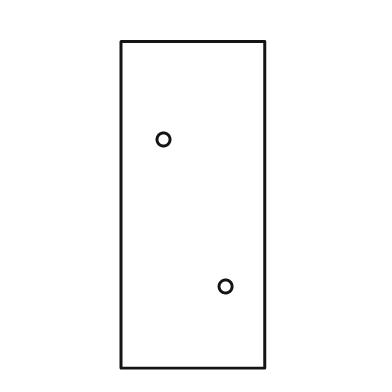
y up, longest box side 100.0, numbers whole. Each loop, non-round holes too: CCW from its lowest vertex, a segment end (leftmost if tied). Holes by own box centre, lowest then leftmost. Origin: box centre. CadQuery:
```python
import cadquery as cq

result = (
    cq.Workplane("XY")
    .moveTo(-22.0, -50.0)
    .lineTo(22.0, -50.0)
    .lineTo(22.0, 50.0)
    .lineTo(-22.0, 50.0)
    .close()
    .moveTo(10.0, -25.0)
    .circle(2.0)
    .moveTo(-9.0, 20.0)
    .circle(2.0)
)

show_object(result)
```